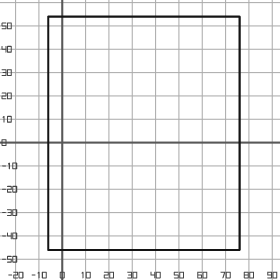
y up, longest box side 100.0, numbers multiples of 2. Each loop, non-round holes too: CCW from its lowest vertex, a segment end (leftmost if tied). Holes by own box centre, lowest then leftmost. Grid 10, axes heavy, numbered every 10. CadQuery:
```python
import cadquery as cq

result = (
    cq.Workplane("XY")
    .moveTo(-6.0, -46.0)
    .lineTo(76.0, -46.0)
    .lineTo(76.0, 54.0)
    .lineTo(-6.0, 54.0)
    .close()
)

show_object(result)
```